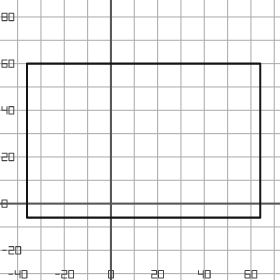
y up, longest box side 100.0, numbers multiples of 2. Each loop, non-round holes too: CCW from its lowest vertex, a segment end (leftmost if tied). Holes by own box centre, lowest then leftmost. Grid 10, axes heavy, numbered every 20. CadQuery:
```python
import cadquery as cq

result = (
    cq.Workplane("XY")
    .moveTo(-36.0, -6.0)
    .lineTo(64.0, -6.0)
    .lineTo(64.0, 60.0)
    .lineTo(-36.0, 60.0)
    .close()
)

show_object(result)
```